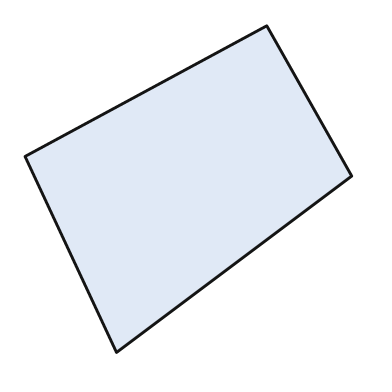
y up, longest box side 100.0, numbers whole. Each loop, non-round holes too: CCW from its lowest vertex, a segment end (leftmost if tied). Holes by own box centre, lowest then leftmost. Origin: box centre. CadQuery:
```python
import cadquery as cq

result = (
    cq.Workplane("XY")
    .moveTo(-22.0, -50.0)
    .lineTo(50.0, 4.0)
    .lineTo(24.0, 50.0)
    .lineTo(-50.0, 10.0)
    .close()
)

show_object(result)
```